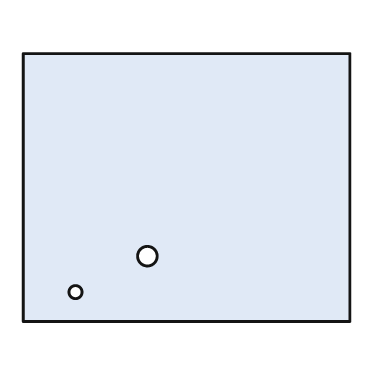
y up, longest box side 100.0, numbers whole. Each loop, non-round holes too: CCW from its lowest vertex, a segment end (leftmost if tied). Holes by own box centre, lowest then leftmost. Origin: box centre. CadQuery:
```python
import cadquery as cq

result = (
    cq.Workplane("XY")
    .moveTo(-50.0, -41.0)
    .lineTo(50.0, -41.0)
    .lineTo(50.0, 41.0)
    .lineTo(-50.0, 41.0)
    .close()
    .moveTo(-34.0, -32.0)
    .circle(2.0)
    .moveTo(-12.0, -21.0)
    .circle(3.0)
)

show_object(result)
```